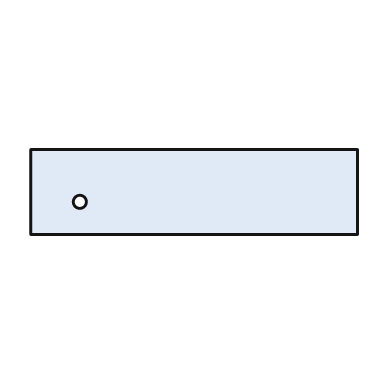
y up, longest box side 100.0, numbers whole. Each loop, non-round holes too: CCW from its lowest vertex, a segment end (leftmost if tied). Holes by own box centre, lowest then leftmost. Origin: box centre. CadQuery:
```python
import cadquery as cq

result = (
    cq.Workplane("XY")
    .moveTo(-50.0, -13.0)
    .lineTo(50.0, -13.0)
    .lineTo(50.0, 13.0)
    .lineTo(-50.0, 13.0)
    .close()
    .moveTo(-35.0, -3.0)
    .circle(2.0)
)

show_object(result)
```